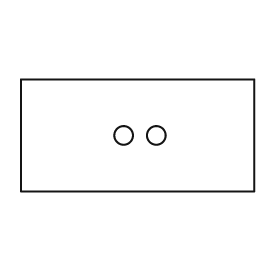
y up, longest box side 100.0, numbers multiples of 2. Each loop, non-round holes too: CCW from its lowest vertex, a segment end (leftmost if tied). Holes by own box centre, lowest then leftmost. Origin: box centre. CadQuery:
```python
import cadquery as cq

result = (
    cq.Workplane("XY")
    .moveTo(-50.0, -24.0)
    .lineTo(50.0, -24.0)
    .lineTo(50.0, 24.0)
    .lineTo(-50.0, 24.0)
    .close()
    .moveTo(-6.0, 0.0)
    .circle(4.0)
    .moveTo(8.0, 0.0)
    .circle(4.0)
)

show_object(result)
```